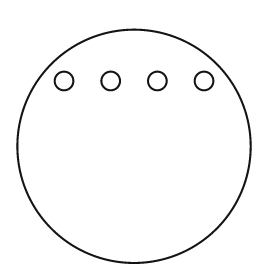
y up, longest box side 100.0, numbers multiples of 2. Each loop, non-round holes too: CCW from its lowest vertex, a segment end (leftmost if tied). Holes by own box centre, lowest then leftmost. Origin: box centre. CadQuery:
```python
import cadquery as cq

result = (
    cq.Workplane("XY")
    .moveTo(0.0, 0.0)
    .circle(50.0)
    .moveTo(-30.0, 28.0)
    .circle(4.0)
    .moveTo(-10.0, 28.0)
    .circle(4.0)
    .moveTo(10.0, 28.0)
    .circle(4.0)
    .moveTo(30.0, 28.0)
    .circle(4.0)
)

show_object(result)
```